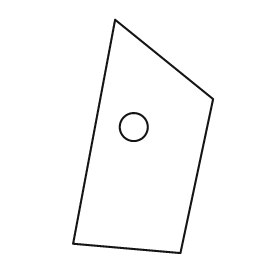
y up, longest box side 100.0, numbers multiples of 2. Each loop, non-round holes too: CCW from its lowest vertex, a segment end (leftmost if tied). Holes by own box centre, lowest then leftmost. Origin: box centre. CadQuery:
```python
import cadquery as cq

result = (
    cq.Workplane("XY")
    .moveTo(16.0, -50.0)
    .lineTo(30.0, 16.0)
    .lineTo(-12.0, 50.0)
    .lineTo(-30.0, -46.0)
    .close()
    .moveTo(-4.0, 4.0)
    .circle(6.0)
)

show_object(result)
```